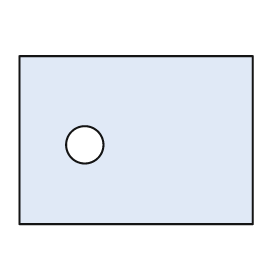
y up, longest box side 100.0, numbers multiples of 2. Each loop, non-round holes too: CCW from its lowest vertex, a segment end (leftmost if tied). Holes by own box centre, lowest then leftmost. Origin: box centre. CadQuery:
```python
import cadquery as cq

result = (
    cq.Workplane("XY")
    .moveTo(-50.0, -36.0)
    .lineTo(50.0, -36.0)
    .lineTo(50.0, 36.0)
    .lineTo(-50.0, 36.0)
    .close()
    .moveTo(-22.0, -2.0)
    .circle(8.0)
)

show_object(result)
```